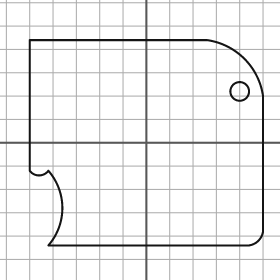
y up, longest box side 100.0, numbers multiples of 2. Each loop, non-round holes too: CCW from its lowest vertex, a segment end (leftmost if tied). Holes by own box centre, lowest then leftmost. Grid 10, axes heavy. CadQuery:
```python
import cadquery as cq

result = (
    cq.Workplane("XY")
    .moveTo(-42.0, -44.0)
    .lineTo(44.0, -44.0)
    .threePointArc((48.0, -42.0), (50.0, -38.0))
    .lineTo(50.0, 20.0)
    .threePointArc((42.0, 36.0), (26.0, 44.0))
    .lineTo(-50.0, 44.0)
    .lineTo(-50.0, -12.0)
    .threePointArc((-46.0, -14.0), (-42.0, -12.0))
    .threePointArc((-36.0, -28.0), (-42.0, -44.0))
    .close()
    .moveTo(40.0, 22.0)
    .circle(4.0)
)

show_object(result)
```